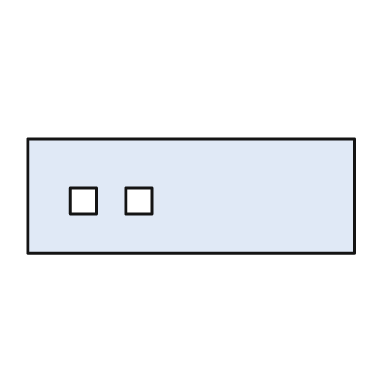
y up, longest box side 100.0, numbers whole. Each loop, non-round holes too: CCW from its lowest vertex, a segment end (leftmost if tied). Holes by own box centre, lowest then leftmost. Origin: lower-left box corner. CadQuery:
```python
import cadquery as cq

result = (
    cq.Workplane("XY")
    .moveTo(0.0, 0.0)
    .lineTo(100.0, 0.0)
    .lineTo(100.0, 35.0)
    .lineTo(0.0, 35.0)
    .close()
    .moveTo(13.0, 12.0)
    .lineTo(21.0, 12.0)
    .lineTo(21.0, 20.0)
    .lineTo(13.0, 20.0)
    .close()
    .moveTo(30.0, 12.0)
    .lineTo(38.0, 12.0)
    .lineTo(38.0, 20.0)
    .lineTo(30.0, 20.0)
    .close()
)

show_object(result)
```